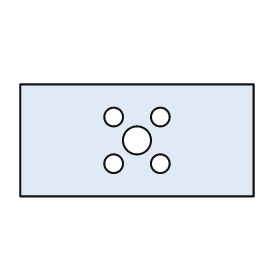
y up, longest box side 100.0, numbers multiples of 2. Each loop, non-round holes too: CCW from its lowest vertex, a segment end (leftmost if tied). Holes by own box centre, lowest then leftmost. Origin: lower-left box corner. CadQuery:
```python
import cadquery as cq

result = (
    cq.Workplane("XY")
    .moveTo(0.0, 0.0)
    .lineTo(100.0, 0.0)
    .lineTo(100.0, 48.0)
    .lineTo(0.0, 48.0)
    .close()
    .moveTo(40.0, 14.0)
    .circle(4.0)
    .moveTo(60.0, 14.0)
    .circle(4.0)
    .moveTo(50.0, 24.0)
    .circle(6.0)
    .moveTo(40.0, 34.0)
    .circle(4.0)
    .moveTo(60.0, 34.0)
    .circle(4.0)
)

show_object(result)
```